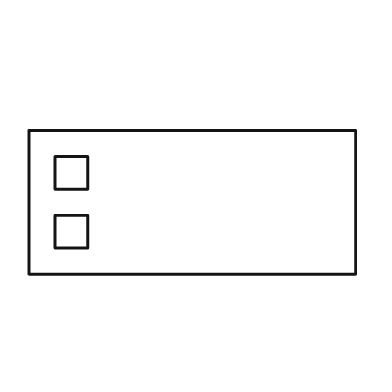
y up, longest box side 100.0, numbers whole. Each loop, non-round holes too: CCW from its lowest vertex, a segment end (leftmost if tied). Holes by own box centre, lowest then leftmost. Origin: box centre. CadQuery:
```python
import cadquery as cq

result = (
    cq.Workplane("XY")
    .moveTo(-50.0, -22.0)
    .lineTo(50.0, -22.0)
    .lineTo(50.0, 22.0)
    .lineTo(-50.0, 22.0)
    .close()
    .moveTo(-42.0, -14.0)
    .lineTo(-32.0, -14.0)
    .lineTo(-32.0, -4.0)
    .lineTo(-42.0, -4.0)
    .close()
    .moveTo(-42.0, 4.0)
    .lineTo(-32.0, 4.0)
    .lineTo(-32.0, 14.0)
    .lineTo(-42.0, 14.0)
    .close()
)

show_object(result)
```